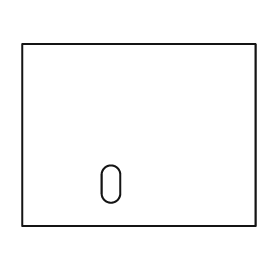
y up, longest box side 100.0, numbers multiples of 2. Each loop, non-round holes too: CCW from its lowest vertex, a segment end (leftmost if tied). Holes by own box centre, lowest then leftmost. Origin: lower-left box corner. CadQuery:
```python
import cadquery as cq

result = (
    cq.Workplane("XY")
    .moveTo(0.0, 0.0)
    .lineTo(100.0, 0.0)
    .lineTo(100.0, 78.0)
    .lineTo(0.0, 78.0)
    .close()
    .moveTo(34.0, 14.0)
    .threePointArc((38.0, 10.0), (42.0, 14.0))
    .lineTo(42.0, 22.0)
    .threePointArc((38.0, 26.0), (34.0, 22.0))
    .close()
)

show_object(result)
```